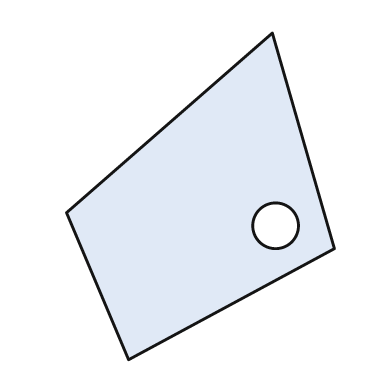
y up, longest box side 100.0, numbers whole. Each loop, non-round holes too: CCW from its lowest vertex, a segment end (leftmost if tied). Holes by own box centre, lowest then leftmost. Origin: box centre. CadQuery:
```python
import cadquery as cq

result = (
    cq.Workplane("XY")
    .moveTo(-22.0, -50.0)
    .lineTo(41.0, -16.0)
    .lineTo(22.0, 50.0)
    .lineTo(-41.0, -5.0)
    .close()
    .moveTo(23.0, -9.0)
    .circle(7.0)
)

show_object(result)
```